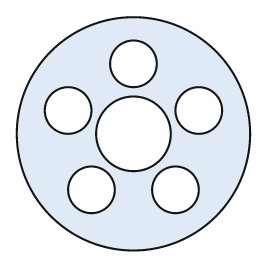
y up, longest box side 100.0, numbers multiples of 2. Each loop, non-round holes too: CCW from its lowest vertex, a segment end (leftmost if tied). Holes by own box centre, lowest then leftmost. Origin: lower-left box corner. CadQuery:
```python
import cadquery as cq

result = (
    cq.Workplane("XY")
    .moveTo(50.0, 50.0)
    .circle(50.0)
    .moveTo(32.0, 26.0)
    .circle(10.0)
    .moveTo(68.0, 26.0)
    .circle(10.0)
    .moveTo(50.0, 50.0)
    .circle(16.0)
    .moveTo(22.0, 60.0)
    .circle(10.0)
    .moveTo(78.0, 60.0)
    .circle(10.0)
    .moveTo(50.0, 80.0)
    .circle(10.0)
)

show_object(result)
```